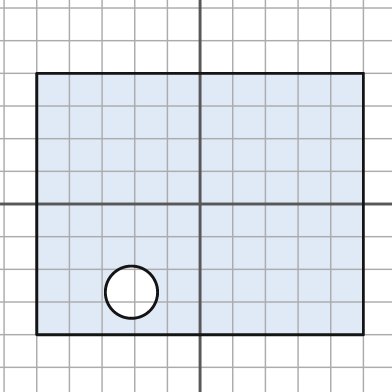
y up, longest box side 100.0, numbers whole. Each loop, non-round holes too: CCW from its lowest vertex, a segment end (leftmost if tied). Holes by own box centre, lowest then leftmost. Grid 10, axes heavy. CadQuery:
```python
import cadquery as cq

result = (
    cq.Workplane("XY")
    .moveTo(-50.0, -40.0)
    .lineTo(50.0, -40.0)
    .lineTo(50.0, 40.0)
    .lineTo(-50.0, 40.0)
    .close()
    .moveTo(-21.0, -27.0)
    .circle(8.0)
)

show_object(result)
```